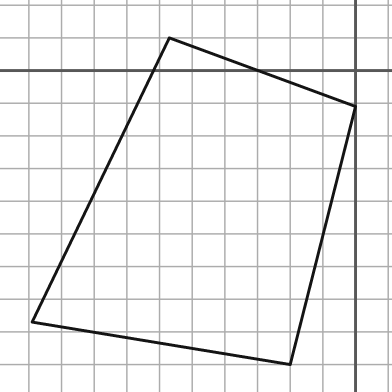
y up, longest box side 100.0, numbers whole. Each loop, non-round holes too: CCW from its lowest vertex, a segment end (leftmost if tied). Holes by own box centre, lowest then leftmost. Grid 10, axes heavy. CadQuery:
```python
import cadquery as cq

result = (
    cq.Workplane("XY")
    .moveTo(-20.0, -90.0)
    .lineTo(0.0, -11.0)
    .lineTo(-57.0, 10.0)
    .lineTo(-99.0, -77.0)
    .close()
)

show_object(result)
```